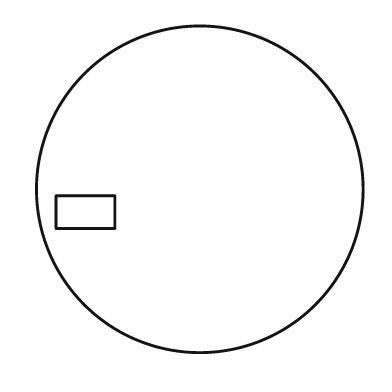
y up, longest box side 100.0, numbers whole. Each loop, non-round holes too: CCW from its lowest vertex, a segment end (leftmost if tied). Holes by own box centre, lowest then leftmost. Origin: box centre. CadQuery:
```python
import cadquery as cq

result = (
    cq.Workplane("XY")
    .moveTo(0.0, 0.0)
    .circle(50.0)
    .moveTo(-44.0, -12.0)
    .lineTo(-26.0, -12.0)
    .lineTo(-26.0, -2.0)
    .lineTo(-44.0, -2.0)
    .close()
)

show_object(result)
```